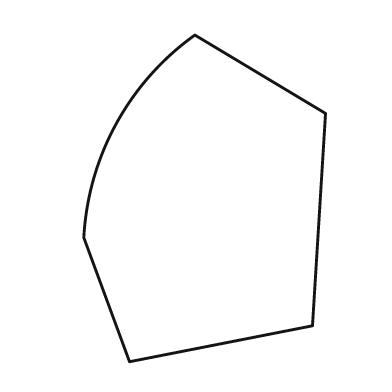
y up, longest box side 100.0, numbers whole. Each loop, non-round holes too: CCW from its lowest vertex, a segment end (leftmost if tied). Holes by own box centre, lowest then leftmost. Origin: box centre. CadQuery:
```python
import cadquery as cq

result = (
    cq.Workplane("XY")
    .moveTo(-23.0, -50.0)
    .lineTo(33.0, -39.0)
    .lineTo(37.0, 26.0)
    .lineTo(-3.0, 50.0)
    .threePointArc((-27.0, 23.0), (-37.0, -12.0))
    .close()
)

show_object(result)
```